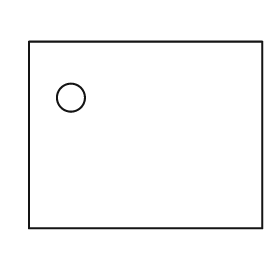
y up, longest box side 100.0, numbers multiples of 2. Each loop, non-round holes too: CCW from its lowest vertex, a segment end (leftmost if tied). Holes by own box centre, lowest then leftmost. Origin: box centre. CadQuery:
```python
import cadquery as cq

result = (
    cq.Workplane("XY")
    .moveTo(-50.0, -40.0)
    .lineTo(50.0, -40.0)
    .lineTo(50.0, 40.0)
    .lineTo(-50.0, 40.0)
    .close()
    .moveTo(-32.0, 16.0)
    .circle(6.0)
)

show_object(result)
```